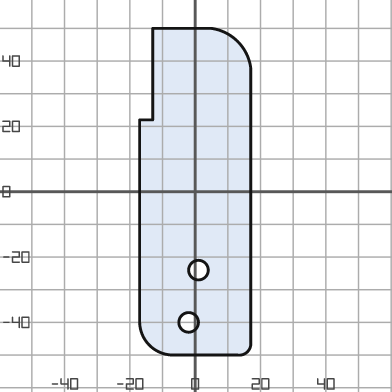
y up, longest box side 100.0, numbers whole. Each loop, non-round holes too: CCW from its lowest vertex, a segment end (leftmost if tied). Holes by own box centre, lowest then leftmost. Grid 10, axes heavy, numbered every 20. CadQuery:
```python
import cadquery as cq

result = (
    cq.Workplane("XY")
    .moveTo(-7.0, -50.0)
    .lineTo(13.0, -50.0)
    .threePointArc((16.0, -49.0), (17.0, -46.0))
    .lineTo(17.0, 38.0)
    .threePointArc((13.0, 46.0), (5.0, 50.0))
    .lineTo(-13.0, 50.0)
    .lineTo(-13.0, 22.0)
    .lineTo(-17.0, 22.0)
    .lineTo(-17.0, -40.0)
    .threePointArc((-14.0, -47.0), (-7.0, -50.0))
    .close()
    .moveTo(-2.0, -40.0)
    .circle(3.0)
    .moveTo(1.0, -24.0)
    .circle(3.0)
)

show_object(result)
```